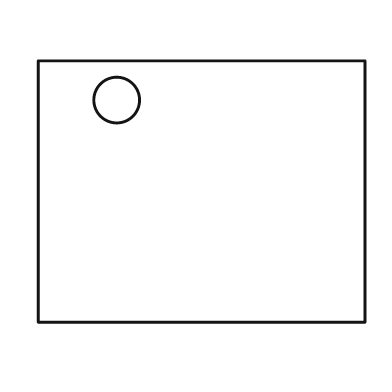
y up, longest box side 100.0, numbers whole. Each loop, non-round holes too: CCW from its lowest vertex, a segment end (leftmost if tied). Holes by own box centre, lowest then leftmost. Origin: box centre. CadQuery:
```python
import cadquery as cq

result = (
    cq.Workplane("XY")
    .moveTo(-50.0, -40.0)
    .lineTo(50.0, -40.0)
    .lineTo(50.0, 40.0)
    .lineTo(-50.0, 40.0)
    .close()
    .moveTo(-26.0, 28.0)
    .circle(7.0)
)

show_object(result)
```